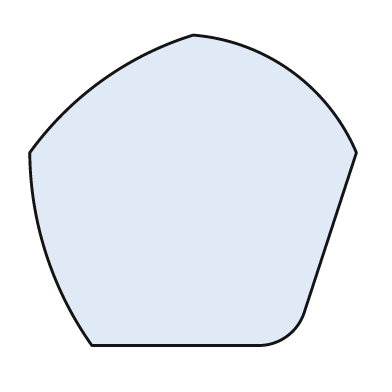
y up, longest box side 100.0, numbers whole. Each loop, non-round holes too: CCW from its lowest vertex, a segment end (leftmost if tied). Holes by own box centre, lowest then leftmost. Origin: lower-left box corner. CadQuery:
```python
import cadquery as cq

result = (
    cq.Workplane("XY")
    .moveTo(19.0, 0.0)
    .lineTo(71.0, 0.0)
    .threePointArc((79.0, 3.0), (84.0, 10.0))
    .lineTo(100.0, 59.0)
    .threePointArc((80.0, 84.0), (50.0, 95.0))
    .threePointArc((22.0, 81.0), (0.0, 59.0))
    .threePointArc((5.0, 28.0), (19.0, 0.0))
    .close()
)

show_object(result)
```